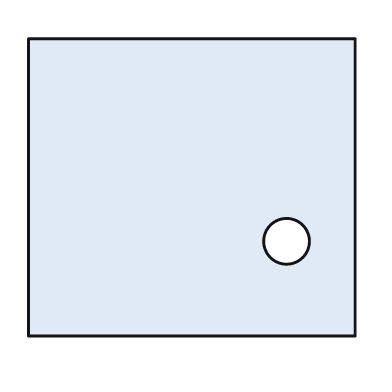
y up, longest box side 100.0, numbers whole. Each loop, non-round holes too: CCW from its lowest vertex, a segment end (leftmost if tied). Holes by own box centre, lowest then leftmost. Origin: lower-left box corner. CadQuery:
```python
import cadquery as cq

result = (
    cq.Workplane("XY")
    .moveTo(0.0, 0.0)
    .lineTo(100.0, 0.0)
    .lineTo(100.0, 91.0)
    .lineTo(0.0, 91.0)
    .close()
    .moveTo(79.0, 29.0)
    .circle(7.0)
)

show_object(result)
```